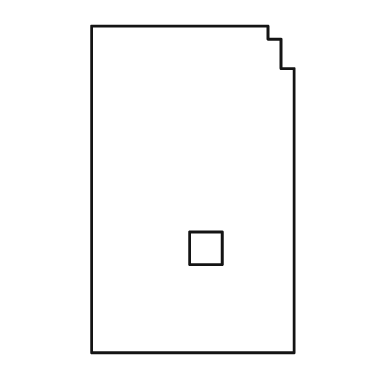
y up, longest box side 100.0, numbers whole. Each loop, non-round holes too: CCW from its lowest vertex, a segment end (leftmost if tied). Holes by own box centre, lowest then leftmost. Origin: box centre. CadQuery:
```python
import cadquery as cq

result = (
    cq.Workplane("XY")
    .moveTo(-31.0, -50.0)
    .lineTo(31.0, -50.0)
    .lineTo(31.0, 37.0)
    .lineTo(27.0, 37.0)
    .lineTo(27.0, 46.0)
    .lineTo(23.0, 46.0)
    .lineTo(23.0, 50.0)
    .lineTo(-31.0, 50.0)
    .close()
    .moveTo(-1.0, -23.0)
    .lineTo(9.0, -23.0)
    .lineTo(9.0, -13.0)
    .lineTo(-1.0, -13.0)
    .close()
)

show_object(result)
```